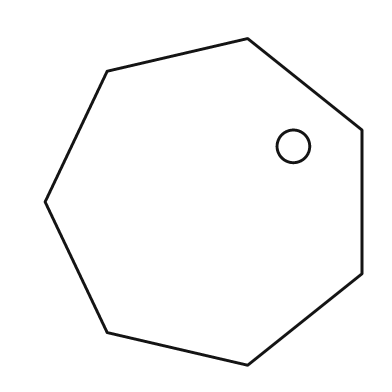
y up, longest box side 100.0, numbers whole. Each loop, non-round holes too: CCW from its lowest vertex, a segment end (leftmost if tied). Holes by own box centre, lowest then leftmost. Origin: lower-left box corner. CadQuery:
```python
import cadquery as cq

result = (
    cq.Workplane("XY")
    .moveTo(62.0, 0.0)
    .lineTo(97.0, 28.0)
    .lineTo(97.0, 72.0)
    .lineTo(62.0, 100.0)
    .lineTo(19.0, 90.0)
    .lineTo(0.0, 50.0)
    .lineTo(19.0, 10.0)
    .close()
    .moveTo(76.0, 67.0)
    .circle(5.0)
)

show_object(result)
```